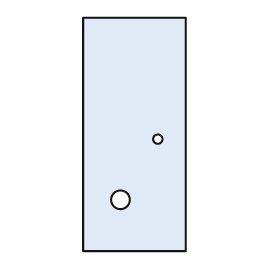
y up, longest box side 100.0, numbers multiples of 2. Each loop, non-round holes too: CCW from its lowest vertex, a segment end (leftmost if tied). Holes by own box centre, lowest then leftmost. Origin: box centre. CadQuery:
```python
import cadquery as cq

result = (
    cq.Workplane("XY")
    .moveTo(-22.0, -50.0)
    .lineTo(22.0, -50.0)
    .lineTo(22.0, 50.0)
    .lineTo(-22.0, 50.0)
    .close()
    .moveTo(-6.0, -28.0)
    .circle(4.0)
    .moveTo(10.0, -2.0)
    .circle(2.0)
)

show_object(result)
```